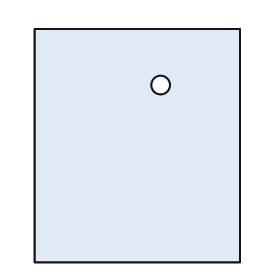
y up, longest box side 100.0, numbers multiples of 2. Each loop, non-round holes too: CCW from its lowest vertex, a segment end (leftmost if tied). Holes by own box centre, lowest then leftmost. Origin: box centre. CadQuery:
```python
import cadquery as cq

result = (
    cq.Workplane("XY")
    .moveTo(-44.0, -50.0)
    .lineTo(44.0, -50.0)
    .lineTo(44.0, 50.0)
    .lineTo(-44.0, 50.0)
    .close()
    .moveTo(10.0, 26.0)
    .circle(4.0)
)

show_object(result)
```